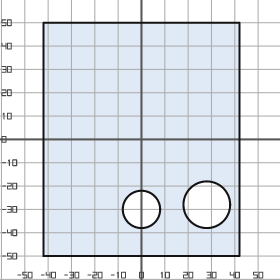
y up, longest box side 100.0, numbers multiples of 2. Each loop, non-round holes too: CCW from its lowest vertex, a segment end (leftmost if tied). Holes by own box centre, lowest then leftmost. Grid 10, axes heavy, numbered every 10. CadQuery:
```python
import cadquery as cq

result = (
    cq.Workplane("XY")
    .moveTo(-42.0, -50.0)
    .lineTo(42.0, -50.0)
    .lineTo(42.0, 50.0)
    .lineTo(-42.0, 50.0)
    .close()
    .moveTo(0.0, -30.0)
    .circle(8.0)
    .moveTo(28.0, -28.0)
    .circle(10.0)
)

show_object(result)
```